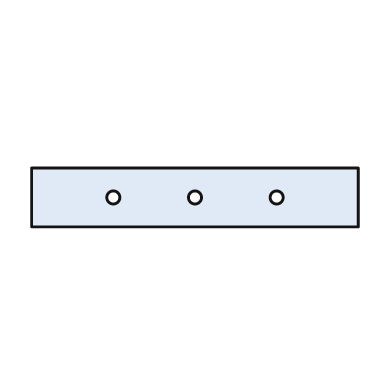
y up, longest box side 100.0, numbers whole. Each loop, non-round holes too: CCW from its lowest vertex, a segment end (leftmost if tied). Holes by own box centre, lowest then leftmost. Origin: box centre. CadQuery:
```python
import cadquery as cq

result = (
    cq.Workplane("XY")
    .moveTo(-50.0, -9.0)
    .lineTo(50.0, -9.0)
    .lineTo(50.0, 9.0)
    .lineTo(-50.0, 9.0)
    .close()
    .moveTo(-25.0, 0.0)
    .circle(2.0)
    .moveTo(0.0, 0.0)
    .circle(2.0)
    .moveTo(25.0, 0.0)
    .circle(2.0)
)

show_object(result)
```